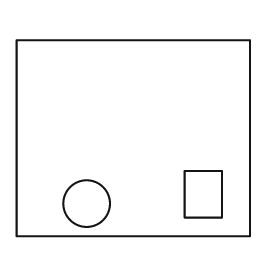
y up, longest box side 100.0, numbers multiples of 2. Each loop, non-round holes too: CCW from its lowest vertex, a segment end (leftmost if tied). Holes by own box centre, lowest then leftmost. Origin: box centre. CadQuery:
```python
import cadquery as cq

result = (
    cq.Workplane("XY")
    .moveTo(-50.0, -42.0)
    .lineTo(50.0, -42.0)
    .lineTo(50.0, 42.0)
    .lineTo(-50.0, 42.0)
    .close()
    .moveTo(-20.0, -28.0)
    .circle(10.0)
    .moveTo(22.0, -34.0)
    .lineTo(38.0, -34.0)
    .lineTo(38.0, -14.0)
    .lineTo(22.0, -14.0)
    .close()
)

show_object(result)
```